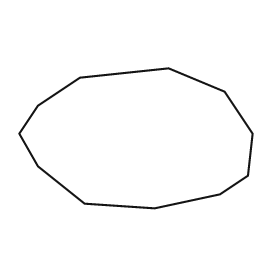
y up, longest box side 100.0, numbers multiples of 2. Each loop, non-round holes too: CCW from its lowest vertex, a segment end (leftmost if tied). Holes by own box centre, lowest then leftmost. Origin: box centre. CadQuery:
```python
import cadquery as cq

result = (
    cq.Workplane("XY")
    .moveTo(8.0, -30.0)
    .lineTo(36.0, -24.0)
    .lineTo(48.0, -16.0)
    .lineTo(50.0, 2.0)
    .lineTo(38.0, 20.0)
    .lineTo(14.0, 30.0)
    .lineTo(-24.0, 26.0)
    .lineTo(-42.0, 14.0)
    .lineTo(-50.0, 2.0)
    .lineTo(-42.0, -12.0)
    .lineTo(-22.0, -28.0)
    .close()
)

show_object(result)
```